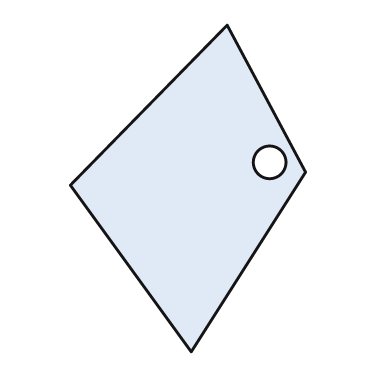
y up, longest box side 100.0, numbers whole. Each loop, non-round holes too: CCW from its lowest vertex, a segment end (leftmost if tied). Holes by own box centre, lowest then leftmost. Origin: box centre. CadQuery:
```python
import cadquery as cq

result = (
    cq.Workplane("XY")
    .moveTo(1.0, -50.0)
    .lineTo(36.0, 5.0)
    .lineTo(12.0, 50.0)
    .lineTo(-36.0, 1.0)
    .close()
    .moveTo(25.0, 8.0)
    .circle(5.0)
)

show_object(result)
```